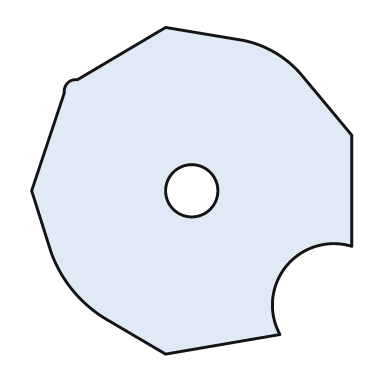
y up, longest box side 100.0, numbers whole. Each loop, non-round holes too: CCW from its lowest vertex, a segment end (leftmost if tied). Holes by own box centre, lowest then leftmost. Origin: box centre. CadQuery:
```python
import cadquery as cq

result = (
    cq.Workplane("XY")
    .moveTo(-8.0, -50.0)
    .lineTo(27.0, -44.0)
    .threePointArc((29.0, -23.0), (49.0, -17.0))
    .lineTo(49.0, 17.0)
    .lineTo(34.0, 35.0)
    .threePointArc((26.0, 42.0), (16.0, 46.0))
    .lineTo(-8.0, 50.0)
    .lineTo(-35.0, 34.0)
    .threePointArc((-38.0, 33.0), (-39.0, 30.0))
    .lineTo(-49.0, 0.0)
    .lineTo(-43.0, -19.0)
    .threePointArc((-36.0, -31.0), (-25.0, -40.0))
    .close()
    .moveTo(0.0, 0.0)
    .circle(8.0)
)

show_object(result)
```